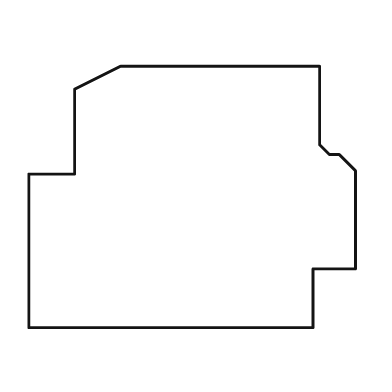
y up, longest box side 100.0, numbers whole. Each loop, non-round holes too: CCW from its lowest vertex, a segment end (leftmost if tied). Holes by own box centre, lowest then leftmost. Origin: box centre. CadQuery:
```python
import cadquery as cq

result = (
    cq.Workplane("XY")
    .moveTo(-50.0, -40.0)
    .lineTo(37.0, -40.0)
    .lineTo(37.0, -22.0)
    .lineTo(50.0, -22.0)
    .lineTo(50.0, 8.0)
    .lineTo(45.0, 13.0)
    .lineTo(42.0, 13.0)
    .lineTo(39.0, 16.0)
    .lineTo(39.0, 40.0)
    .lineTo(-22.0, 40.0)
    .lineTo(-36.0, 33.0)
    .lineTo(-36.0, 7.0)
    .lineTo(-50.0, 7.0)
    .close()
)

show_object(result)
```